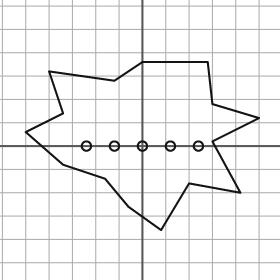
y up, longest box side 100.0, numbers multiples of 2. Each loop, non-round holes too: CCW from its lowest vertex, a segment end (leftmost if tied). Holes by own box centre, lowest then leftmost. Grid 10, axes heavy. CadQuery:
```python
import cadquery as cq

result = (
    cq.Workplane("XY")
    .moveTo(8.0, -36.0)
    .lineTo(20.0, -16.0)
    .lineTo(42.0, -20.0)
    .lineTo(30.0, 2.0)
    .lineTo(50.0, 12.0)
    .lineTo(30.0, 18.0)
    .lineTo(28.0, 36.0)
    .lineTo(0.0, 36.0)
    .lineTo(-12.0, 28.0)
    .lineTo(-40.0, 32.0)
    .lineTo(-34.0, 14.0)
    .lineTo(-50.0, 6.0)
    .lineTo(-34.0, -8.0)
    .lineTo(-16.0, -14.0)
    .lineTo(-6.0, -26.0)
    .close()
    .moveTo(-24.0, 0.0)
    .circle(2.0)
    .moveTo(-12.0, 0.0)
    .circle(2.0)
    .moveTo(0.0, 0.0)
    .circle(2.0)
    .moveTo(12.0, 0.0)
    .circle(2.0)
    .moveTo(24.0, 0.0)
    .circle(2.0)
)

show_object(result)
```